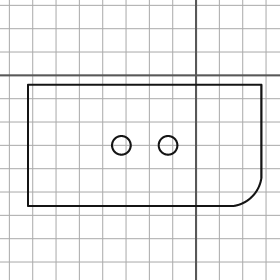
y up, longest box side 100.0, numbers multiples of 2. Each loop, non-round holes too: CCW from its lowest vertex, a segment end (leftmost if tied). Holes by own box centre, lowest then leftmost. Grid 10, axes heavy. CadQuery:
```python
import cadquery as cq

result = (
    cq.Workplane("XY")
    .moveTo(-72.0, -56.0)
    .lineTo(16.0, -56.0)
    .threePointArc((24.0, -52.0), (28.0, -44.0))
    .lineTo(28.0, -4.0)
    .lineTo(-72.0, -4.0)
    .close()
    .moveTo(-32.0, -30.0)
    .circle(4.0)
    .moveTo(-12.0, -30.0)
    .circle(4.0)
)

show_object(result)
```